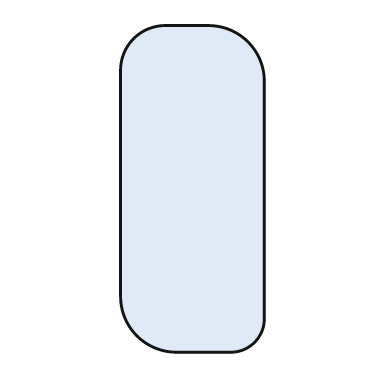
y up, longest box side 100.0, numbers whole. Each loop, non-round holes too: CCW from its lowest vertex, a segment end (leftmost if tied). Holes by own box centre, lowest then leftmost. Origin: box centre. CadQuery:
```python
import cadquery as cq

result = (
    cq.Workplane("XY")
    .moveTo(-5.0, -50.0)
    .lineTo(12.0, -50.0)
    .threePointArc((19.0, -47.0), (22.0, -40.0))
    .lineTo(22.0, 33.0)
    .threePointArc((17.0, 45.0), (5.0, 50.0))
    .lineTo(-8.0, 50.0)
    .threePointArc((-18.0, 46.0), (-22.0, 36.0))
    .lineTo(-22.0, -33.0)
    .threePointArc((-17.0, -45.0), (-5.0, -50.0))
    .close()
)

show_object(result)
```